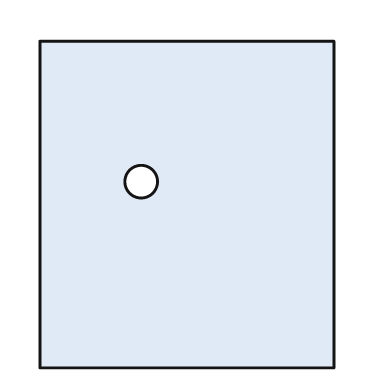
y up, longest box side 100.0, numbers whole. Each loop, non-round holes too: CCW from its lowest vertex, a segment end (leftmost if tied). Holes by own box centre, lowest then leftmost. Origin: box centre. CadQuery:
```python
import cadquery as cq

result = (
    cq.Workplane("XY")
    .moveTo(-45.0, -50.0)
    .lineTo(45.0, -50.0)
    .lineTo(45.0, 50.0)
    .lineTo(-45.0, 50.0)
    .close()
    .moveTo(-14.0, 7.0)
    .circle(5.0)
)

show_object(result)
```